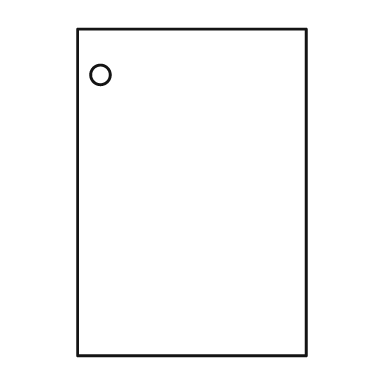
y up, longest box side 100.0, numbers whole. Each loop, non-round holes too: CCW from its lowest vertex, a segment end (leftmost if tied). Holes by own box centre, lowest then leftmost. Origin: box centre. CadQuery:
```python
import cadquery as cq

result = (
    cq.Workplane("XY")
    .moveTo(-35.0, -50.0)
    .lineTo(35.0, -50.0)
    .lineTo(35.0, 50.0)
    .lineTo(-35.0, 50.0)
    .close()
    .moveTo(-28.0, 36.0)
    .circle(3.0)
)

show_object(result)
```